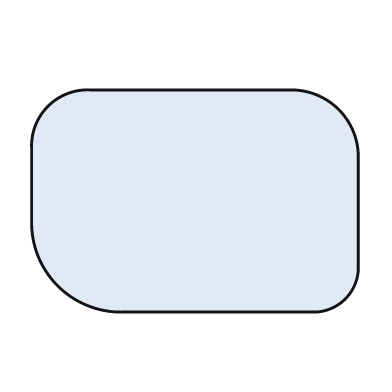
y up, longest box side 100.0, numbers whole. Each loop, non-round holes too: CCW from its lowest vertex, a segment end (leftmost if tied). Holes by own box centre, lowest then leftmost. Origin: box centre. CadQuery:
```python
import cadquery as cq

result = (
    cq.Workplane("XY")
    .moveTo(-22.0, -34.0)
    .lineTo(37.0, -34.0)
    .threePointArc((46.0, -30.0), (50.0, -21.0))
    .lineTo(50.0, 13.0)
    .threePointArc((44.0, 28.0), (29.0, 34.0))
    .lineTo(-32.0, 34.0)
    .threePointArc((-45.0, 29.0), (-50.0, 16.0))
    .lineTo(-50.0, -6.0)
    .threePointArc((-42.0, -26.0), (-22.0, -34.0))
    .close()
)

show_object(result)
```